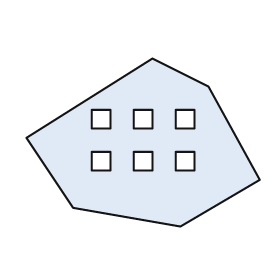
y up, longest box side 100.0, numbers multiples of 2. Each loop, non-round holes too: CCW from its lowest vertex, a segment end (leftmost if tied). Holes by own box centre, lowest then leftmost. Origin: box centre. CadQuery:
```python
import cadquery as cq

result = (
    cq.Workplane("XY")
    .moveTo(16.0, -36.0)
    .lineTo(50.0, -16.0)
    .lineTo(28.0, 24.0)
    .lineTo(4.0, 36.0)
    .lineTo(-50.0, 2.0)
    .lineTo(-30.0, -28.0)
    .close()
    .moveTo(-22.0, -12.0)
    .lineTo(-14.0, -12.0)
    .lineTo(-14.0, -4.0)
    .lineTo(-22.0, -4.0)
    .close()
    .moveTo(-4.0, -12.0)
    .lineTo(4.0, -12.0)
    .lineTo(4.0, -4.0)
    .lineTo(-4.0, -4.0)
    .close()
    .moveTo(14.0, -12.0)
    .lineTo(22.0, -12.0)
    .lineTo(22.0, -4.0)
    .lineTo(14.0, -4.0)
    .close()
    .moveTo(-22.0, 6.0)
    .lineTo(-14.0, 6.0)
    .lineTo(-14.0, 14.0)
    .lineTo(-22.0, 14.0)
    .close()
    .moveTo(-4.0, 6.0)
    .lineTo(4.0, 6.0)
    .lineTo(4.0, 14.0)
    .lineTo(-4.0, 14.0)
    .close()
    .moveTo(14.0, 6.0)
    .lineTo(22.0, 6.0)
    .lineTo(22.0, 14.0)
    .lineTo(14.0, 14.0)
    .close()
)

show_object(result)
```